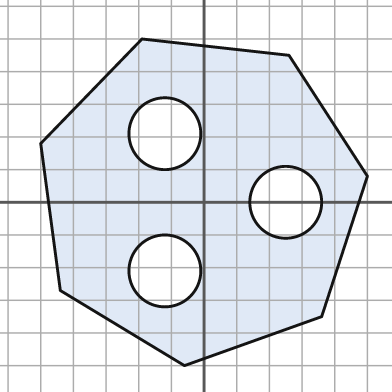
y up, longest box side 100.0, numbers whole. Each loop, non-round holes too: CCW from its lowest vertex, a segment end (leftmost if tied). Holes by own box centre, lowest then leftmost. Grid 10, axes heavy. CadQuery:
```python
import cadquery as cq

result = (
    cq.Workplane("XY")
    .moveTo(-6.0, -50.0)
    .lineTo(36.0, -35.0)
    .lineTo(50.0, 8.0)
    .lineTo(26.0, 45.0)
    .lineTo(-19.0, 50.0)
    .lineTo(-50.0, 18.0)
    .lineTo(-44.0, -27.0)
    .close()
    .moveTo(-12.0, -21.0)
    .circle(11.0)
    .moveTo(25.0, 0.0)
    .circle(11.0)
    .moveTo(-12.0, 21.0)
    .circle(11.0)
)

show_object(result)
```